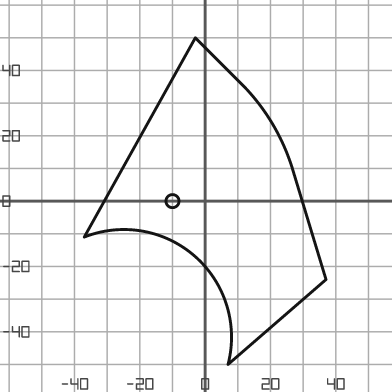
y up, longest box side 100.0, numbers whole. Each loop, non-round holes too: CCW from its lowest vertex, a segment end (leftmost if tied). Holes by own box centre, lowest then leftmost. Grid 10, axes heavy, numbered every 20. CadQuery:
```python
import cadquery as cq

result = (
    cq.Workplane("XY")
    .moveTo(7.0, -50.0)
    .lineTo(37.0, -24.0)
    .lineTo(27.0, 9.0)
    .threePointArc((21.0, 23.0), (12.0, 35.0))
    .lineTo(-3.0, 50.0)
    .lineTo(-37.0, -11.0)
    .threePointArc((-3.0, -17.0), (7.0, -50.0))
    .close()
    .moveTo(-10.0, 0.0)
    .circle(2.0)
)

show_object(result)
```